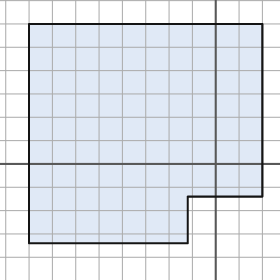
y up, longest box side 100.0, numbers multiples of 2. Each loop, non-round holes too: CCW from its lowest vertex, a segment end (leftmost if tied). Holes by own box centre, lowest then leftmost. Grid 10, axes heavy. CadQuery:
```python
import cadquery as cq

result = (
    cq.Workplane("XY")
    .moveTo(-80.0, -34.0)
    .lineTo(-12.0, -34.0)
    .lineTo(-12.0, -14.0)
    .lineTo(20.0, -14.0)
    .lineTo(20.0, 60.0)
    .lineTo(-80.0, 60.0)
    .close()
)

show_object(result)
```